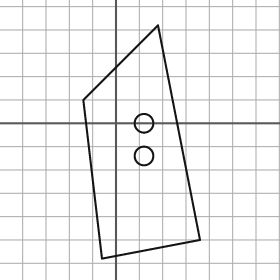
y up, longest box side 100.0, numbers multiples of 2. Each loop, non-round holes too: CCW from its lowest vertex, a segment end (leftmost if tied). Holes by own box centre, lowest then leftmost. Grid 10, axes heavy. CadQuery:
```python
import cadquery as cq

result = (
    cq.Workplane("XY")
    .moveTo(-6.0, -58.0)
    .lineTo(36.0, -50.0)
    .lineTo(18.0, 42.0)
    .lineTo(-14.0, 10.0)
    .close()
    .moveTo(12.0, -14.0)
    .circle(4.0)
    .moveTo(12.0, 0.0)
    .circle(4.0)
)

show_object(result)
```